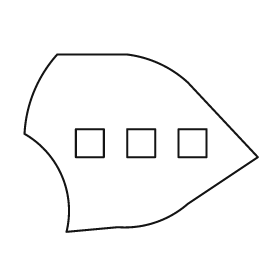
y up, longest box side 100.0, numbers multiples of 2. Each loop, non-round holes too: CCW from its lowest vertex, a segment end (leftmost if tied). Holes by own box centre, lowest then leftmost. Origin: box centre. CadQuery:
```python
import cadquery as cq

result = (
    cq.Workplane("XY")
    .moveTo(-32.0, -38.0)
    .lineTo(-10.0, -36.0)
    .threePointArc((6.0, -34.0), (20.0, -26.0))
    .lineTo(50.0, -6.0)
    .lineTo(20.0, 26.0)
    .threePointArc((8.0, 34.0), (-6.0, 38.0))
    .lineTo(-36.0, 38.0)
    .threePointArc((-46.0, 22.0), (-50.0, 4.0))
    .threePointArc((-34.0, -14.0), (-32.0, -38.0))
    .close()
    .moveTo(-28.0, -6.0)
    .lineTo(-16.0, -6.0)
    .lineTo(-16.0, 6.0)
    .lineTo(-28.0, 6.0)
    .close()
    .moveTo(-6.0, -6.0)
    .lineTo(6.0, -6.0)
    .lineTo(6.0, 6.0)
    .lineTo(-6.0, 6.0)
    .close()
    .moveTo(16.0, -6.0)
    .lineTo(28.0, -6.0)
    .lineTo(28.0, 6.0)
    .lineTo(16.0, 6.0)
    .close()
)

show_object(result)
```